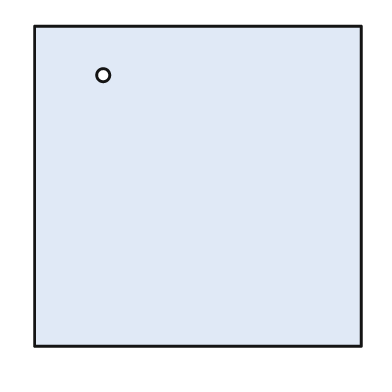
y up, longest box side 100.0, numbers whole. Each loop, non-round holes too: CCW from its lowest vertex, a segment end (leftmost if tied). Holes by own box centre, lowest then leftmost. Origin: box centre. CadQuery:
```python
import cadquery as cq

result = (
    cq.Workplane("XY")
    .moveTo(-50.0, -49.0)
    .lineTo(50.0, -49.0)
    .lineTo(50.0, 49.0)
    .lineTo(-50.0, 49.0)
    .close()
    .moveTo(-29.0, 34.0)
    .circle(2.0)
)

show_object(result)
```